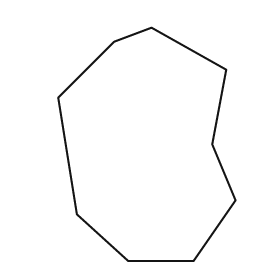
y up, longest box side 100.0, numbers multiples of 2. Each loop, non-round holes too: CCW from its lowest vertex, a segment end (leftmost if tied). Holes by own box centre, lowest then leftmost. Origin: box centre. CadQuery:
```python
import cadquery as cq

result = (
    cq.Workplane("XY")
    .moveTo(-8.0, -50.0)
    .lineTo(20.0, -50.0)
    .lineTo(38.0, -24.0)
    .lineTo(28.0, 0.0)
    .lineTo(34.0, 32.0)
    .lineTo(2.0, 50.0)
    .lineTo(-14.0, 44.0)
    .lineTo(-38.0, 20.0)
    .lineTo(-30.0, -30.0)
    .close()
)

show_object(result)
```